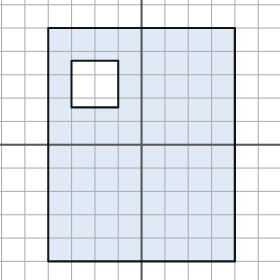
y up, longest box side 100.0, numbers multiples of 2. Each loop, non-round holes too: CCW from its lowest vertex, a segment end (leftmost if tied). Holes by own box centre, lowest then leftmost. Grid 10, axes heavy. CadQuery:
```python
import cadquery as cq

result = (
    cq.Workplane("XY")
    .moveTo(-40.0, -50.0)
    .lineTo(40.0, -50.0)
    .lineTo(40.0, 50.0)
    .lineTo(-40.0, 50.0)
    .close()
    .moveTo(-30.0, 16.0)
    .lineTo(-10.0, 16.0)
    .lineTo(-10.0, 36.0)
    .lineTo(-30.0, 36.0)
    .close()
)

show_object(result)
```